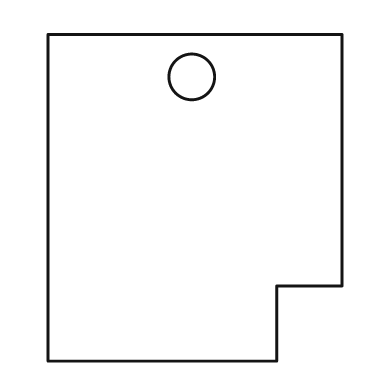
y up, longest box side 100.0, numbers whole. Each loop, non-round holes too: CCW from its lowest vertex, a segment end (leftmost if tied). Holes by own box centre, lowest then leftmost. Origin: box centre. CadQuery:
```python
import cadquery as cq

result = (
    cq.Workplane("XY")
    .moveTo(-45.0, -50.0)
    .lineTo(25.0, -50.0)
    .lineTo(25.0, -27.0)
    .lineTo(45.0, -27.0)
    .lineTo(45.0, 50.0)
    .lineTo(-45.0, 50.0)
    .close()
    .moveTo(-1.0, 37.0)
    .circle(7.0)
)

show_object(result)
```